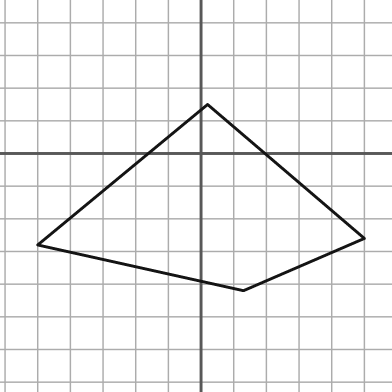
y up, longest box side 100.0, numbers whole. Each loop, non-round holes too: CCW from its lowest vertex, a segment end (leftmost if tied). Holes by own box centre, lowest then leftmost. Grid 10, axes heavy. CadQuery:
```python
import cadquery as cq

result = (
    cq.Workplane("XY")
    .moveTo(13.0, -42.0)
    .lineTo(50.0, -26.0)
    .lineTo(2.0, 15.0)
    .lineTo(-50.0, -28.0)
    .close()
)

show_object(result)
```